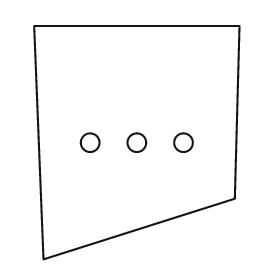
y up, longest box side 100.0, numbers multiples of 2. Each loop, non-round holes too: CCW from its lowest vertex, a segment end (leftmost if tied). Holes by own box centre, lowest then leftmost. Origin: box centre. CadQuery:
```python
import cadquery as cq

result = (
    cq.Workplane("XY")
    .moveTo(-40.0, -50.0)
    .lineTo(42.0, -24.0)
    .lineTo(44.0, 50.0)
    .lineTo(-44.0, 50.0)
    .close()
    .moveTo(-20.0, 0.0)
    .circle(4.0)
    .moveTo(0.0, 0.0)
    .circle(4.0)
    .moveTo(20.0, 0.0)
    .circle(4.0)
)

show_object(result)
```